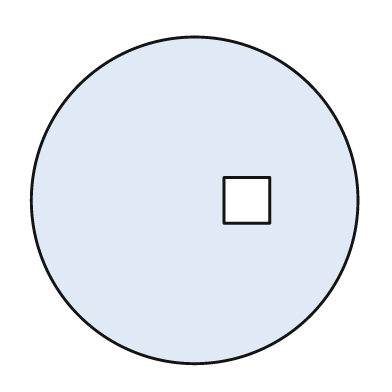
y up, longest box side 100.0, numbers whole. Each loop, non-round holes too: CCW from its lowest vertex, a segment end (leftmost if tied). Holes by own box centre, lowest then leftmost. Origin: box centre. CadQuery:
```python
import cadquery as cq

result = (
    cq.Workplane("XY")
    .moveTo(0.0, 0.0)
    .circle(50.0)
    .moveTo(9.0, -7.0)
    .lineTo(23.0, -7.0)
    .lineTo(23.0, 7.0)
    .lineTo(9.0, 7.0)
    .close()
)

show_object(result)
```